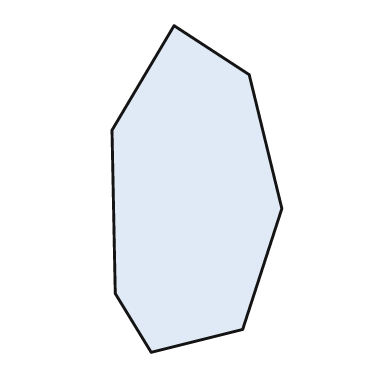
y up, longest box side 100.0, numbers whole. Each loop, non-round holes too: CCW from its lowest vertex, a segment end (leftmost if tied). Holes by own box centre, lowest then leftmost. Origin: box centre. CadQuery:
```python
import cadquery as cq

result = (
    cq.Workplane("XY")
    .moveTo(-14.0, -50.0)
    .lineTo(14.0, -43.0)
    .lineTo(26.0, -6.0)
    .lineTo(16.0, 35.0)
    .lineTo(-7.0, 50.0)
    .lineTo(-26.0, 18.0)
    .lineTo(-25.0, -32.0)
    .close()
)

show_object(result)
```